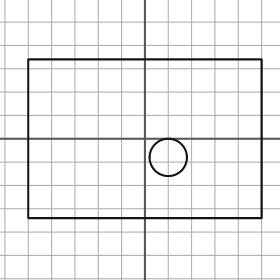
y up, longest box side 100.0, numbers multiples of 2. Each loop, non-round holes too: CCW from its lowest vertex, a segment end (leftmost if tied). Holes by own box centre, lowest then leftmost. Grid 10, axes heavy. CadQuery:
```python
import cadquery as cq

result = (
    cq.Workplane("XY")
    .moveTo(-50.0, -34.0)
    .lineTo(50.0, -34.0)
    .lineTo(50.0, 34.0)
    .lineTo(-50.0, 34.0)
    .close()
    .moveTo(10.0, -8.0)
    .circle(8.0)
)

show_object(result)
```